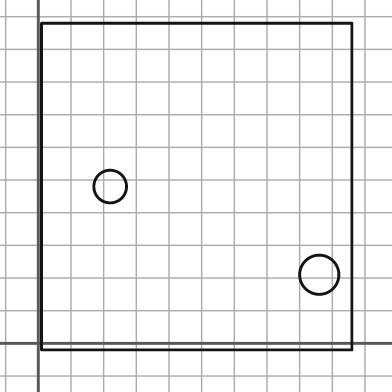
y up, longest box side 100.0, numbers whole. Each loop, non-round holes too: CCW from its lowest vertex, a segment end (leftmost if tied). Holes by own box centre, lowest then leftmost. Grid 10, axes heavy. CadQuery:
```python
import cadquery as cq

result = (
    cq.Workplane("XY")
    .moveTo(1.0, -2.0)
    .lineTo(96.0, -2.0)
    .lineTo(96.0, 98.0)
    .lineTo(1.0, 98.0)
    .close()
    .moveTo(86.0, 21.0)
    .circle(6.0)
    .moveTo(22.0, 48.0)
    .circle(5.0)
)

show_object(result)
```